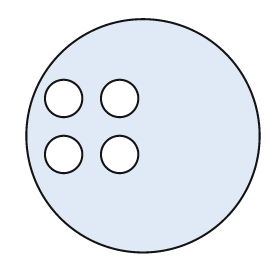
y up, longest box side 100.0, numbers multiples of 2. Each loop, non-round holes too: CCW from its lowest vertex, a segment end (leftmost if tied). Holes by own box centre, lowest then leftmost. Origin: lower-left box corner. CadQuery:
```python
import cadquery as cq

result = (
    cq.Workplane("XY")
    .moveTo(50.0, 50.0)
    .circle(50.0)
    .moveTo(16.0, 42.0)
    .circle(8.0)
    .moveTo(40.0, 42.0)
    .circle(8.0)
    .moveTo(16.0, 66.0)
    .circle(8.0)
    .moveTo(40.0, 66.0)
    .circle(8.0)
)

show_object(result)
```